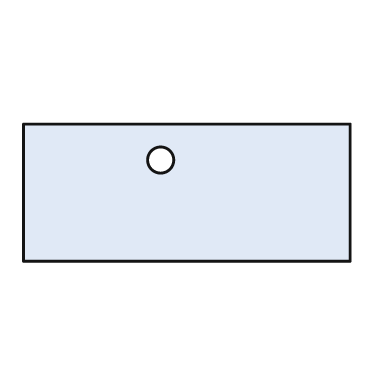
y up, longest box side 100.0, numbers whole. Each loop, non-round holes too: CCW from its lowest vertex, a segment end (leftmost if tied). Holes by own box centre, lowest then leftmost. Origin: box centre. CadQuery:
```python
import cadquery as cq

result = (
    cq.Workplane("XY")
    .moveTo(-50.0, -21.0)
    .lineTo(50.0, -21.0)
    .lineTo(50.0, 21.0)
    .lineTo(-50.0, 21.0)
    .close()
    .moveTo(-8.0, 10.0)
    .circle(4.0)
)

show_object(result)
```